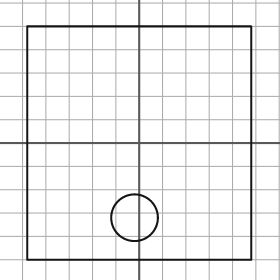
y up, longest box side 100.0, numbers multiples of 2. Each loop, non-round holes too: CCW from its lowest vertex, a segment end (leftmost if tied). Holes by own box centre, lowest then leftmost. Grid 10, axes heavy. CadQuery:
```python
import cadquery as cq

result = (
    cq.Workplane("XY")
    .moveTo(-48.0, -50.0)
    .lineTo(48.0, -50.0)
    .lineTo(48.0, 50.0)
    .lineTo(-48.0, 50.0)
    .close()
    .moveTo(-2.0, -32.0)
    .circle(10.0)
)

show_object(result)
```